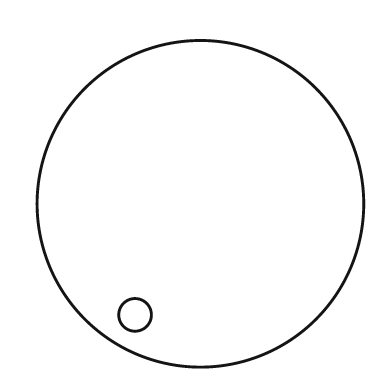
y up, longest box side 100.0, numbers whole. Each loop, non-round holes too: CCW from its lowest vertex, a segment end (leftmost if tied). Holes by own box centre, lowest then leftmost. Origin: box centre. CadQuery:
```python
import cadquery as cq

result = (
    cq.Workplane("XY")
    .moveTo(0.0, 0.0)
    .circle(50.0)
    .moveTo(-20.0, -34.0)
    .circle(5.0)
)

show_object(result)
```